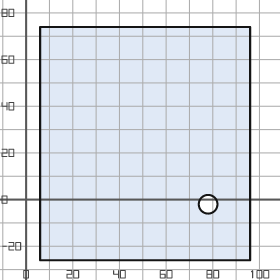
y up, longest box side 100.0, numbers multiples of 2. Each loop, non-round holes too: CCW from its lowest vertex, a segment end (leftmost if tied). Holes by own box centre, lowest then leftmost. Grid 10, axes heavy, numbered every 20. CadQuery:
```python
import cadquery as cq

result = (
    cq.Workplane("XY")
    .moveTo(6.0, -26.0)
    .lineTo(96.0, -26.0)
    .lineTo(96.0, 74.0)
    .lineTo(6.0, 74.0)
    .close()
    .moveTo(78.0, -2.0)
    .circle(4.0)
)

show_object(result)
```